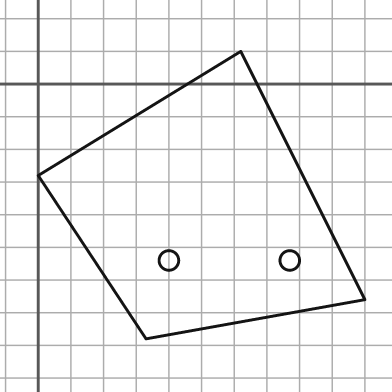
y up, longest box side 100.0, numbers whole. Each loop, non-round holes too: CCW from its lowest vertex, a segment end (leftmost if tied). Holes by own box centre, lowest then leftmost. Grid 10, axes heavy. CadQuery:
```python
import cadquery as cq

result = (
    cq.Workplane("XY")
    .moveTo(33.0, -78.0)
    .lineTo(100.0, -66.0)
    .lineTo(62.0, 10.0)
    .lineTo(0.0, -28.0)
    .close()
    .moveTo(40.0, -54.0)
    .circle(3.0)
    .moveTo(77.0, -54.0)
    .circle(3.0)
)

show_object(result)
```